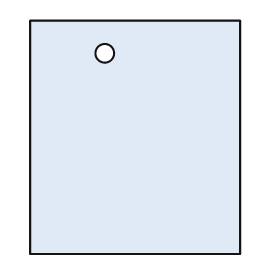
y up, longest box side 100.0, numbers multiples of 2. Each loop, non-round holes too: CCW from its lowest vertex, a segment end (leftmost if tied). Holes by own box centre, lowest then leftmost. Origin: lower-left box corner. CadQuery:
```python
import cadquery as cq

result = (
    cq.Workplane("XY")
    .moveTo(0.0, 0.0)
    .lineTo(90.0, 0.0)
    .lineTo(90.0, 100.0)
    .lineTo(0.0, 100.0)
    .close()
    .moveTo(32.0, 86.0)
    .circle(4.0)
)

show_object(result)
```